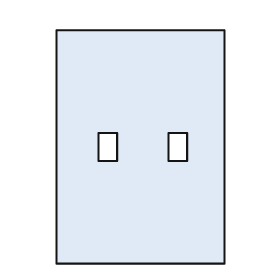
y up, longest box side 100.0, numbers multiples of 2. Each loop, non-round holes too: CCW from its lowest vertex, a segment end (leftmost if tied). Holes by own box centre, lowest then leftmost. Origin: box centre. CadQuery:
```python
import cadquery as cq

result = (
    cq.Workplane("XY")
    .moveTo(-36.0, -50.0)
    .lineTo(36.0, -50.0)
    .lineTo(36.0, 50.0)
    .lineTo(-36.0, 50.0)
    .close()
    .moveTo(-18.0, -6.0)
    .lineTo(-10.0, -6.0)
    .lineTo(-10.0, 6.0)
    .lineTo(-18.0, 6.0)
    .close()
    .moveTo(12.0, -6.0)
    .lineTo(20.0, -6.0)
    .lineTo(20.0, 6.0)
    .lineTo(12.0, 6.0)
    .close()
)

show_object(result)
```